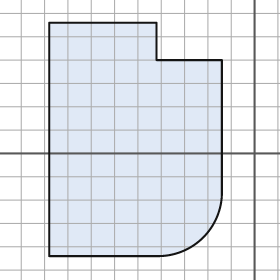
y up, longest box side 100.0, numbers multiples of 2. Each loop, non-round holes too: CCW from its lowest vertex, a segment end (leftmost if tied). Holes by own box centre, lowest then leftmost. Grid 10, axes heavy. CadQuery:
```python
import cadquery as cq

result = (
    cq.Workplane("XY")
    .moveTo(-88.0, -44.0)
    .lineTo(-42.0, -44.0)
    .threePointArc((-22.0, -36.0), (-14.0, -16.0))
    .lineTo(-14.0, 40.0)
    .lineTo(-42.0, 40.0)
    .lineTo(-42.0, 56.0)
    .lineTo(-88.0, 56.0)
    .close()
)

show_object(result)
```